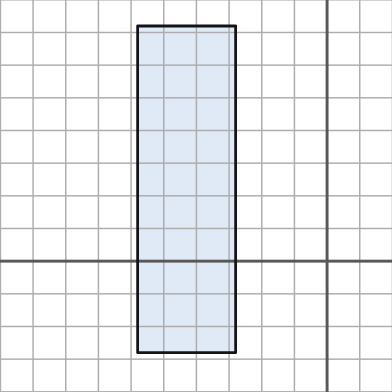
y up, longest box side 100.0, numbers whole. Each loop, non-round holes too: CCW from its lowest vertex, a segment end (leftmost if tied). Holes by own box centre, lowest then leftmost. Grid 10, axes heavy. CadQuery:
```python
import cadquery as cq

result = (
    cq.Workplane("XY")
    .moveTo(-58.0, -28.0)
    .lineTo(-28.0, -28.0)
    .lineTo(-28.0, 72.0)
    .lineTo(-58.0, 72.0)
    .close()
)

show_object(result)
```